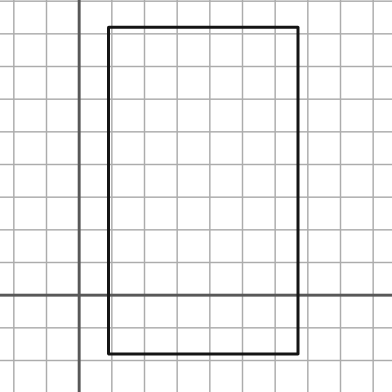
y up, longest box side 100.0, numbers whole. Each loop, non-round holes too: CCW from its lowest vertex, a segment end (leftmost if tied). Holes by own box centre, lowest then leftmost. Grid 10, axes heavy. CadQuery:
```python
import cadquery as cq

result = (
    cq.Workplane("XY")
    .moveTo(9.0, -18.0)
    .lineTo(67.0, -18.0)
    .lineTo(67.0, 82.0)
    .lineTo(9.0, 82.0)
    .close()
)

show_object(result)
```